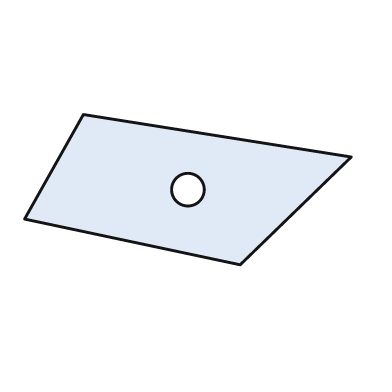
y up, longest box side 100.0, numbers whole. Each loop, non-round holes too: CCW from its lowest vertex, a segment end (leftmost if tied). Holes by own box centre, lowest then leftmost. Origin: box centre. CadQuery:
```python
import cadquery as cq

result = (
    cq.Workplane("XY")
    .moveTo(16.0, -23.0)
    .lineTo(50.0, 10.0)
    .lineTo(-32.0, 23.0)
    .lineTo(-50.0, -9.0)
    .close()
    .moveTo(0.0, 0.0)
    .circle(5.0)
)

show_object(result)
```